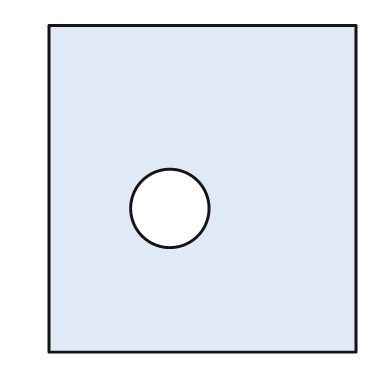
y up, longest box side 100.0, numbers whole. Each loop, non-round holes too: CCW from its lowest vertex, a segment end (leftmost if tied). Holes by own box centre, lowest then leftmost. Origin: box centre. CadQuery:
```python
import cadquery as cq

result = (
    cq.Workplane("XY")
    .moveTo(-47.0, -50.0)
    .lineTo(47.0, -50.0)
    .lineTo(47.0, 50.0)
    .lineTo(-47.0, 50.0)
    .close()
    .moveTo(-10.0, -6.0)
    .circle(12.0)
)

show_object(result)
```